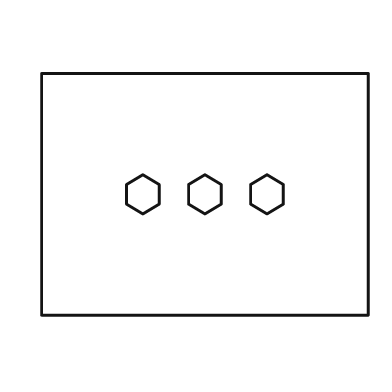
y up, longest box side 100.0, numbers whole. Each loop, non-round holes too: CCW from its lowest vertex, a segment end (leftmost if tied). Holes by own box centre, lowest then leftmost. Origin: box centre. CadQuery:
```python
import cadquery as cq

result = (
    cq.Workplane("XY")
    .moveTo(-50.0, -37.0)
    .lineTo(50.0, -37.0)
    .lineTo(50.0, 37.0)
    .lineTo(-50.0, 37.0)
    .close()
    .moveTo(-19.0, -6.0)
    .lineTo(-14.0, -3.0)
    .lineTo(-14.0, 3.0)
    .lineTo(-19.0, 6.0)
    .lineTo(-24.0, 3.0)
    .lineTo(-24.0, -3.0)
    .close()
    .moveTo(0.0, -6.0)
    .lineTo(5.0, -3.0)
    .lineTo(5.0, 3.0)
    .lineTo(0.0, 6.0)
    .lineTo(-5.0, 3.0)
    .lineTo(-5.0, -3.0)
    .close()
    .moveTo(19.0, -6.0)
    .lineTo(24.0, -3.0)
    .lineTo(24.0, 3.0)
    .lineTo(19.0, 6.0)
    .lineTo(14.0, 3.0)
    .lineTo(14.0, -3.0)
    .close()
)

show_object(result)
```